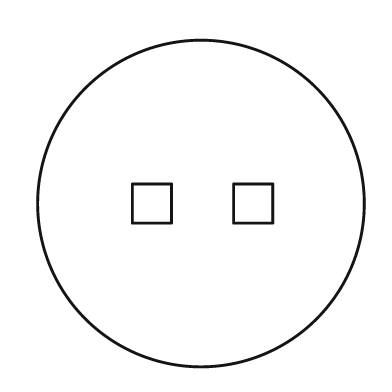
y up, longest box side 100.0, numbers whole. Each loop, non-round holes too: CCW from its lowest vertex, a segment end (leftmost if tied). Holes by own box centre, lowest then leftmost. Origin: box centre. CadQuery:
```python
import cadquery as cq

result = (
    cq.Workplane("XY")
    .moveTo(0.0, 0.0)
    .circle(50.0)
    .moveTo(-21.0, -6.0)
    .lineTo(-9.0, -6.0)
    .lineTo(-9.0, 6.0)
    .lineTo(-21.0, 6.0)
    .close()
    .moveTo(10.0, -6.0)
    .lineTo(22.0, -6.0)
    .lineTo(22.0, 6.0)
    .lineTo(10.0, 6.0)
    .close()
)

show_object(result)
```